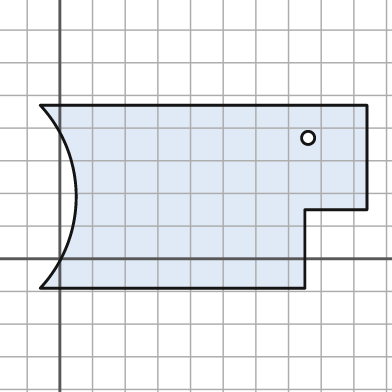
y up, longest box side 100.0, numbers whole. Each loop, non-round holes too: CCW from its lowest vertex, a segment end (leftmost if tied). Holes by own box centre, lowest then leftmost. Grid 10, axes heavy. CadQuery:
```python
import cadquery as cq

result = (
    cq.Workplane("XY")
    .moveTo(-6.0, -9.0)
    .lineTo(75.0, -9.0)
    .lineTo(75.0, 15.0)
    .lineTo(94.0, 15.0)
    .lineTo(94.0, 47.0)
    .lineTo(-6.0, 47.0)
    .threePointArc((5.0, 19.0), (-6.0, -9.0))
    .close()
    .moveTo(76.0, 37.0)
    .circle(2.0)
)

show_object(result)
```